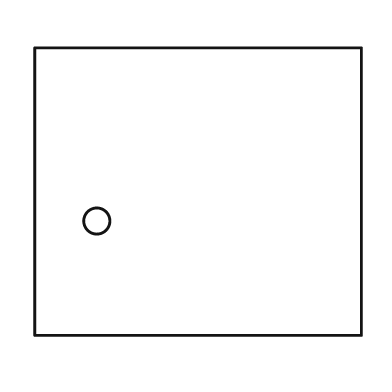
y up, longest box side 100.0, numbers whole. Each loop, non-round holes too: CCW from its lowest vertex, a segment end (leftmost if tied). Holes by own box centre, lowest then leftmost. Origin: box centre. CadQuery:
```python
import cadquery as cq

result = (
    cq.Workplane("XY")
    .moveTo(-50.0, -44.0)
    .lineTo(50.0, -44.0)
    .lineTo(50.0, 44.0)
    .lineTo(-50.0, 44.0)
    .close()
    .moveTo(-31.0, -9.0)
    .circle(4.0)
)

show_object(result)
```